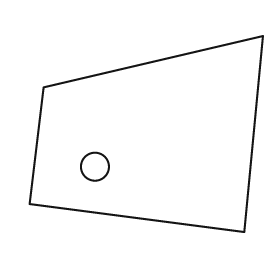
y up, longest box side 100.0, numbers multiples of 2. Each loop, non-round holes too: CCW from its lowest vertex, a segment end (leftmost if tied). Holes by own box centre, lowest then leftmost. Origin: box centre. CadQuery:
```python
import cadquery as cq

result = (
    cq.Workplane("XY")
    .moveTo(42.0, -42.0)
    .lineTo(50.0, 42.0)
    .lineTo(-44.0, 20.0)
    .lineTo(-50.0, -30.0)
    .close()
    .moveTo(-22.0, -14.0)
    .circle(6.0)
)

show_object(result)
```